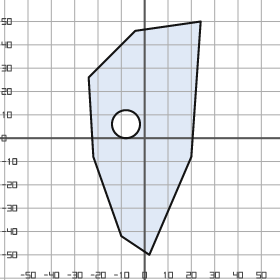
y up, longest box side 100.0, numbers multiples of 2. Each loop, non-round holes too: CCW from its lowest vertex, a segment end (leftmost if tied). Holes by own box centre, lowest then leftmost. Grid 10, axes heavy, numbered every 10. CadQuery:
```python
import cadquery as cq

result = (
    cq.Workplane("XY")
    .moveTo(2.0, -50.0)
    .lineTo(20.0, -8.0)
    .lineTo(24.0, 50.0)
    .lineTo(-4.0, 46.0)
    .lineTo(-24.0, 26.0)
    .lineTo(-22.0, -8.0)
    .lineTo(-10.0, -42.0)
    .close()
    .moveTo(-8.0, 6.0)
    .circle(6.0)
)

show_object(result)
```